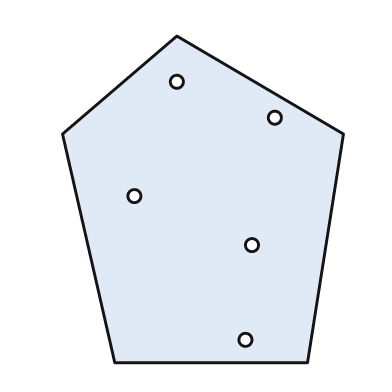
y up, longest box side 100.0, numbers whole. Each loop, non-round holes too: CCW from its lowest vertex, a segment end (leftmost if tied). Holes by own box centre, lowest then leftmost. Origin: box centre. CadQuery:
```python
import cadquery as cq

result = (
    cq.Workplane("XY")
    .moveTo(-27.0, -50.0)
    .lineTo(32.0, -50.0)
    .lineTo(43.0, 20.0)
    .lineTo(-8.0, 50.0)
    .lineTo(-43.0, 20.0)
    .close()
    .moveTo(13.0, -43.0)
    .circle(2.0)
    .moveTo(15.0, -14.0)
    .circle(2.0)
    .moveTo(-21.0, 1.0)
    .circle(2.0)
    .moveTo(22.0, 25.0)
    .circle(2.0)
    .moveTo(-8.0, 36.0)
    .circle(2.0)
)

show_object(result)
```